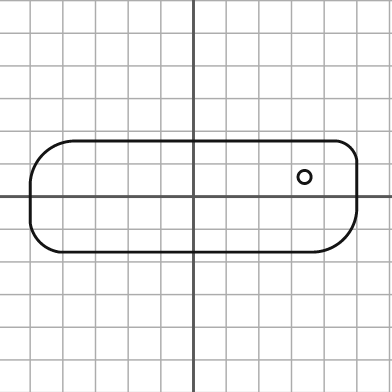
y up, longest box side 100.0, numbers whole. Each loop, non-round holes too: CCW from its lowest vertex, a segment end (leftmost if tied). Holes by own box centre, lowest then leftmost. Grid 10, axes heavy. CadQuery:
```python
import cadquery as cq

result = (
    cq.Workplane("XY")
    .moveTo(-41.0, -17.0)
    .lineTo(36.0, -17.0)
    .threePointArc((46.0, -13.0), (50.0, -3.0))
    .lineTo(50.0, 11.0)
    .threePointArc((48.0, 15.0), (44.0, 17.0))
    .lineTo(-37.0, 17.0)
    .threePointArc((-46.0, 13.0), (-50.0, 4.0))
    .lineTo(-50.0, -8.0)
    .threePointArc((-47.0, -14.0), (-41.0, -17.0))
    .close()
    .moveTo(34.0, 6.0)
    .circle(2.0)
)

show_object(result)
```